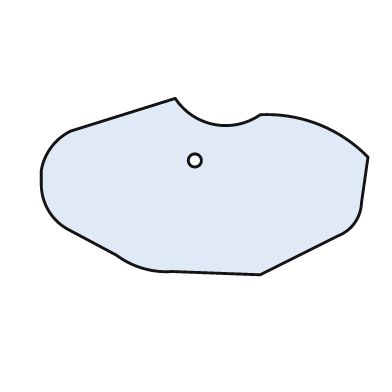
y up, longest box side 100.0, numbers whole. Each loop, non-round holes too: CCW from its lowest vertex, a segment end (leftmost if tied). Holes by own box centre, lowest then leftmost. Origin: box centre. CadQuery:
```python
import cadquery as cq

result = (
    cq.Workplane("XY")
    .moveTo(17.0, -27.0)
    .lineTo(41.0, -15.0)
    .threePointArc((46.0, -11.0), (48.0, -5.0))
    .lineTo(50.0, 9.0)
    .threePointArc((35.0, 19.0), (17.0, 22.0))
    .threePointArc((3.0, 19.0), (-9.0, 27.0))
    .lineTo(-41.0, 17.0)
    .threePointArc((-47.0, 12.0), (-50.0, 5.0))
    .lineTo(-50.0, 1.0)
    .threePointArc((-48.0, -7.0), (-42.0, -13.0))
    .lineTo(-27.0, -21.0)
    .threePointArc((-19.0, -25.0), (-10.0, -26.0))
    .close()
    .moveTo(-3.0, 8.0)
    .circle(2.0)
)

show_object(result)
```